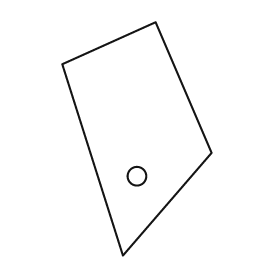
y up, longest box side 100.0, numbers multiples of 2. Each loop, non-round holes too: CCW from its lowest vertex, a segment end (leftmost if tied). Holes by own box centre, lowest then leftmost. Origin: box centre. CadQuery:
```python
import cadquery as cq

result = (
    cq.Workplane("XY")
    .moveTo(-6.0, -50.0)
    .lineTo(32.0, -6.0)
    .lineTo(8.0, 50.0)
    .lineTo(-32.0, 32.0)
    .close()
    .moveTo(0.0, -16.0)
    .circle(4.0)
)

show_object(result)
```